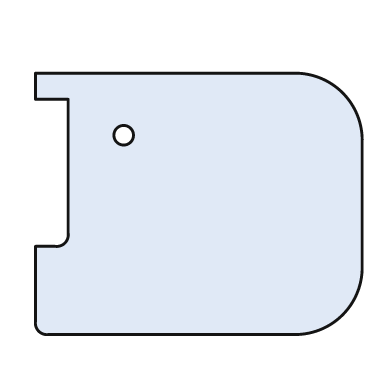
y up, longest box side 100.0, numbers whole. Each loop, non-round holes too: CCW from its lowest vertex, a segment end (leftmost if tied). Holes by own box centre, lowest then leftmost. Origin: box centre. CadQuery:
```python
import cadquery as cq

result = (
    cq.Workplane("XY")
    .moveTo(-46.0, -40.0)
    .lineTo(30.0, -40.0)
    .threePointArc((44.0, -34.0), (50.0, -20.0))
    .lineTo(50.0, 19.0)
    .threePointArc((44.0, 34.0), (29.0, 40.0))
    .lineTo(-50.0, 40.0)
    .lineTo(-50.0, 32.0)
    .lineTo(-40.0, 32.0)
    .lineTo(-40.0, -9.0)
    .threePointArc((-41.0, -12.0), (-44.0, -13.0))
    .lineTo(-50.0, -13.0)
    .lineTo(-50.0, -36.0)
    .threePointArc((-49.0, -39.0), (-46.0, -40.0))
    .close()
    .moveTo(-23.0, 21.0)
    .circle(3.0)
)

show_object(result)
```